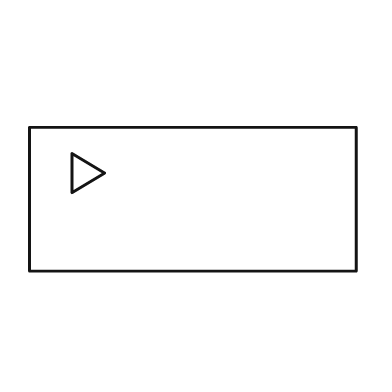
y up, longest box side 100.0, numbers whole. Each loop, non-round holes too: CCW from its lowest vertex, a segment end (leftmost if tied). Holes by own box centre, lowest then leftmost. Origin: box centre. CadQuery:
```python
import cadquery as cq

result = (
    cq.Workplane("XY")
    .moveTo(-50.0, -22.0)
    .lineTo(50.0, -22.0)
    .lineTo(50.0, 22.0)
    .lineTo(-50.0, 22.0)
    .close()
    .moveTo(-37.0, 2.0)
    .lineTo(-27.0, 8.0)
    .lineTo(-37.0, 14.0)
    .close()
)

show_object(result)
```